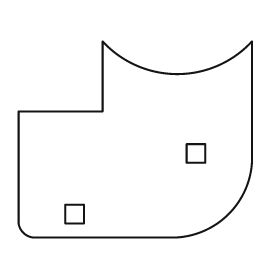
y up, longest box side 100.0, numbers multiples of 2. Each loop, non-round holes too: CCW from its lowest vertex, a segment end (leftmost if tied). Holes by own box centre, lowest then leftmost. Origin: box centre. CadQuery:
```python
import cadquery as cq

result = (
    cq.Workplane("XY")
    .moveTo(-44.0, -42.0)
    .lineTo(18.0, -42.0)
    .threePointArc((40.0, -32.0), (50.0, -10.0))
    .lineTo(50.0, 42.0)
    .threePointArc((18.0, 28.0), (-14.0, 42.0))
    .lineTo(-14.0, 12.0)
    .lineTo(-50.0, 12.0)
    .lineTo(-50.0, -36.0)
    .threePointArc((-48.0, -40.0), (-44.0, -42.0))
    .close()
    .moveTo(-30.0, -36.0)
    .lineTo(-22.0, -36.0)
    .lineTo(-22.0, -28.0)
    .lineTo(-30.0, -28.0)
    .close()
    .moveTo(22.0, -10.0)
    .lineTo(30.0, -10.0)
    .lineTo(30.0, -2.0)
    .lineTo(22.0, -2.0)
    .close()
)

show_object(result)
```